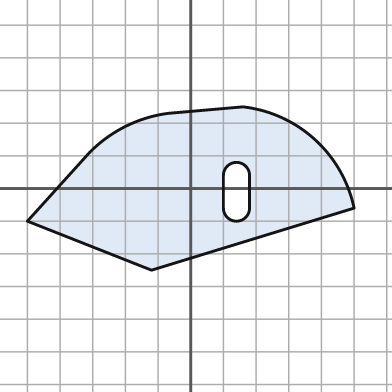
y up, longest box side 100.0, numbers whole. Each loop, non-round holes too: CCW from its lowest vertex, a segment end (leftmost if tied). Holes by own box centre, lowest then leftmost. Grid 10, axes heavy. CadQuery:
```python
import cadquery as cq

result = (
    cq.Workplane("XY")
    .moveTo(-12.0, -25.0)
    .lineTo(50.0, -6.0)
    .threePointArc((38.0, 15.0), (16.0, 25.0))
    .lineTo(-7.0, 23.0)
    .threePointArc((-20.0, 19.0), (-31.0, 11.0))
    .lineTo(-50.0, -10.0)
    .close()
    .moveTo(10.0, -6.0)
    .threePointArc((14.0, -10.0), (18.0, -6.0))
    .lineTo(18.0, 4.0)
    .threePointArc((14.0, 8.0), (10.0, 4.0))
    .close()
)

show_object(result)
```